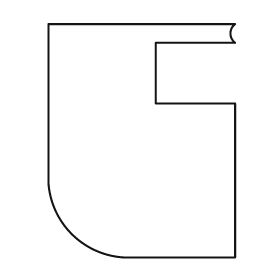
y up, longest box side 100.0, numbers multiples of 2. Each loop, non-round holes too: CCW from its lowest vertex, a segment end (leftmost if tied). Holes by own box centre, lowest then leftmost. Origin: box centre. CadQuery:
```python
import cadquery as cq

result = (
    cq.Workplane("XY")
    .moveTo(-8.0, -50.0)
    .lineTo(40.0, -50.0)
    .lineTo(40.0, 16.0)
    .lineTo(6.0, 16.0)
    .lineTo(6.0, 42.0)
    .lineTo(40.0, 42.0)
    .threePointArc((38.0, 46.0), (40.0, 50.0))
    .lineTo(-40.0, 50.0)
    .lineTo(-40.0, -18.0)
    .threePointArc((-30.0, -40.0), (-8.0, -50.0))
    .close()
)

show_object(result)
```